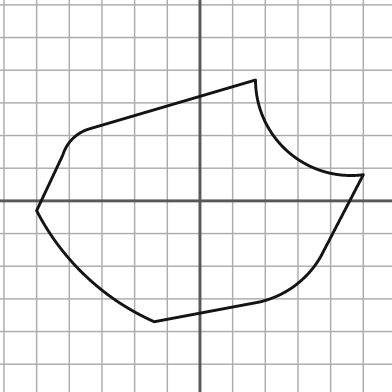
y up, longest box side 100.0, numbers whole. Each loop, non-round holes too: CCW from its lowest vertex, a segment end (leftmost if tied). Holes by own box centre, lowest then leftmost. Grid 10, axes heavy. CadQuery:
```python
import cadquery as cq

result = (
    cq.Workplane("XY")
    .moveTo(-14.0, -37.0)
    .lineTo(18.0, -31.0)
    .threePointArc((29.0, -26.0), (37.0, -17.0))
    .lineTo(50.0, 8.0)
    .threePointArc((27.0, 15.0), (17.0, 37.0))
    .lineTo(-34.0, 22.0)
    .threePointArc((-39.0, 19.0), (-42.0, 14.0))
    .lineTo(-50.0, -3.0)
    .threePointArc((-35.0, -23.0), (-14.0, -37.0))
    .close()
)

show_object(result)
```